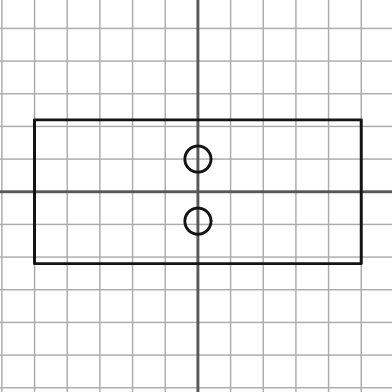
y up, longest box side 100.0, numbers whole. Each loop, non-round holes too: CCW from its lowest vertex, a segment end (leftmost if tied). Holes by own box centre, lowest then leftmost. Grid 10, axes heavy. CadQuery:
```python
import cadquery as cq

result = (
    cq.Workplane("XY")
    .moveTo(-50.0, -22.0)
    .lineTo(50.0, -22.0)
    .lineTo(50.0, 22.0)
    .lineTo(-50.0, 22.0)
    .close()
    .moveTo(0.0, -9.0)
    .circle(4.0)
    .moveTo(0.0, 10.0)
    .circle(4.0)
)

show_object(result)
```